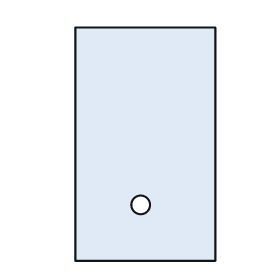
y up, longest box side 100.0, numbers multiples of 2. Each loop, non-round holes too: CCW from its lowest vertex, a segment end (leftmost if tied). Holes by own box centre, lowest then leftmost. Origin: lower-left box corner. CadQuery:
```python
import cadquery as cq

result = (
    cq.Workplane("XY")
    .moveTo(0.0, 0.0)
    .lineTo(60.0, 0.0)
    .lineTo(60.0, 100.0)
    .lineTo(0.0, 100.0)
    .close()
    .moveTo(28.0, 24.0)
    .circle(4.0)
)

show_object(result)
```